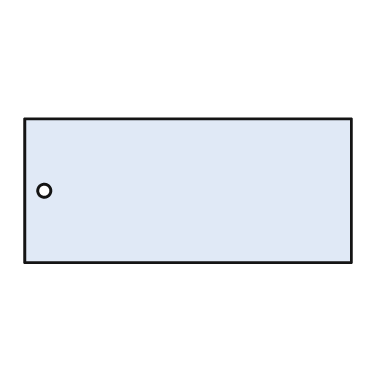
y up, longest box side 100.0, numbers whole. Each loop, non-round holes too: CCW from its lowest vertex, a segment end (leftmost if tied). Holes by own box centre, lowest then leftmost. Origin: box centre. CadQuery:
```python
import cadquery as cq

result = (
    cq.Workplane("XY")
    .moveTo(-50.0, -22.0)
    .lineTo(50.0, -22.0)
    .lineTo(50.0, 22.0)
    .lineTo(-50.0, 22.0)
    .close()
    .moveTo(-44.0, 0.0)
    .circle(2.0)
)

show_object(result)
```